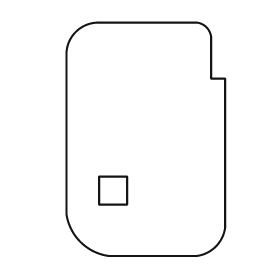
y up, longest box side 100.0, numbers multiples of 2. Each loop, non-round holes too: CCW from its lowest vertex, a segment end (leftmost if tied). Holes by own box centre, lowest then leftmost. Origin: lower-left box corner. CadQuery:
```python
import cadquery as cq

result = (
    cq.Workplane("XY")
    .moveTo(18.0, 0.0)
    .lineTo(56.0, 0.0)
    .threePointArc((64.0, 4.0), (68.0, 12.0))
    .lineTo(68.0, 76.0)
    .lineTo(62.0, 76.0)
    .lineTo(62.0, 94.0)
    .threePointArc((60.0, 98.0), (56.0, 100.0))
    .lineTo(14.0, 100.0)
    .threePointArc((4.0, 96.0), (0.0, 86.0))
    .lineTo(0.0, 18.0)
    .threePointArc((6.0, 6.0), (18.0, 0.0))
    .close()
    .moveTo(14.0, 22.0)
    .lineTo(26.0, 22.0)
    .lineTo(26.0, 34.0)
    .lineTo(14.0, 34.0)
    .close()
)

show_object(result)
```